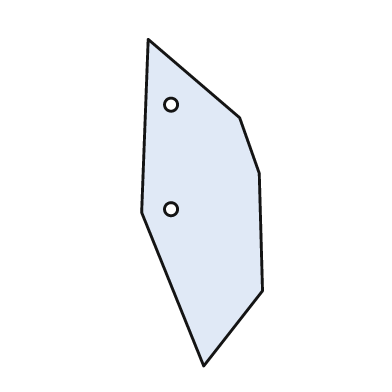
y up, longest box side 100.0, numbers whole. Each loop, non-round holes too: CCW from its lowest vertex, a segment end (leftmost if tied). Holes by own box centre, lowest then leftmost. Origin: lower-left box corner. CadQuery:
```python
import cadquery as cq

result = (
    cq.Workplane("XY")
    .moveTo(19.0, 0.0)
    .lineTo(37.0, 23.0)
    .lineTo(36.0, 59.0)
    .lineTo(30.0, 76.0)
    .lineTo(2.0, 100.0)
    .lineTo(0.0, 47.0)
    .close()
    .moveTo(9.0, 48.0)
    .circle(2.0)
    .moveTo(9.0, 80.0)
    .circle(2.0)
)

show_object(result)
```